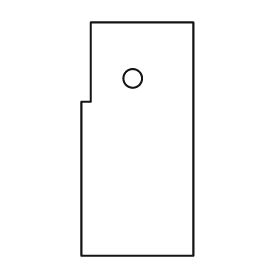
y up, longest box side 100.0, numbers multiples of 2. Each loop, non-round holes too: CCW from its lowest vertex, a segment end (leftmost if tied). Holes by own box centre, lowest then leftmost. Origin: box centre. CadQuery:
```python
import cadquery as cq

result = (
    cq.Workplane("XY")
    .moveTo(-24.0, -50.0)
    .lineTo(24.0, -50.0)
    .lineTo(24.0, 50.0)
    .lineTo(-20.0, 50.0)
    .lineTo(-20.0, 16.0)
    .lineTo(-24.0, 16.0)
    .close()
    .moveTo(-2.0, 26.0)
    .circle(4.0)
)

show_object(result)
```